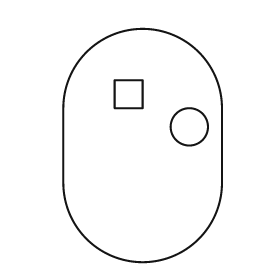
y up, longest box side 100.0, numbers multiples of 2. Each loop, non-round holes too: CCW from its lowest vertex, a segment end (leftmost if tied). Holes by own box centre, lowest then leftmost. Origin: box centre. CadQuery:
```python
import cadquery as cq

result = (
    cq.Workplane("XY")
    .moveTo(-34.0, -16.0)
    .threePointArc((0.0, -50.0), (34.0, -16.0))
    .lineTo(34.0, 16.0)
    .threePointArc((0.0, 50.0), (-34.0, 16.0))
    .close()
    .moveTo(20.0, 8.0)
    .circle(8.0)
    .moveTo(-12.0, 16.0)
    .lineTo(0.0, 16.0)
    .lineTo(0.0, 28.0)
    .lineTo(-12.0, 28.0)
    .close()
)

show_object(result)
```